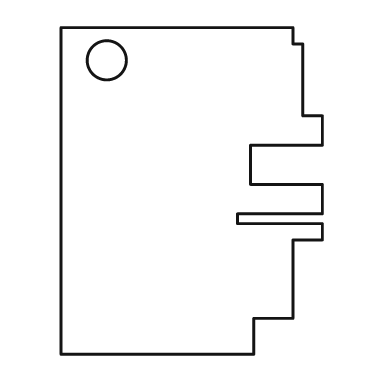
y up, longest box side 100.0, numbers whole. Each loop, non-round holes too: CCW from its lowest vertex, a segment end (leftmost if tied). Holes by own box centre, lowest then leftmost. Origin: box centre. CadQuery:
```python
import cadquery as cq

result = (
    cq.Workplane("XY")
    .moveTo(-40.0, -50.0)
    .lineTo(19.0, -50.0)
    .lineTo(19.0, -39.0)
    .lineTo(31.0, -39.0)
    .lineTo(31.0, -15.0)
    .lineTo(40.0, -15.0)
    .lineTo(40.0, -10.0)
    .lineTo(14.0, -10.0)
    .lineTo(14.0, -7.0)
    .lineTo(40.0, -7.0)
    .lineTo(40.0, 2.0)
    .lineTo(18.0, 2.0)
    .lineTo(18.0, 14.0)
    .lineTo(40.0, 14.0)
    .lineTo(40.0, 23.0)
    .lineTo(34.0, 23.0)
    .lineTo(34.0, 45.0)
    .lineTo(31.0, 45.0)
    .lineTo(31.0, 50.0)
    .lineTo(-40.0, 50.0)
    .close()
    .moveTo(-26.0, 40.0)
    .circle(6.0)
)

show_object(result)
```